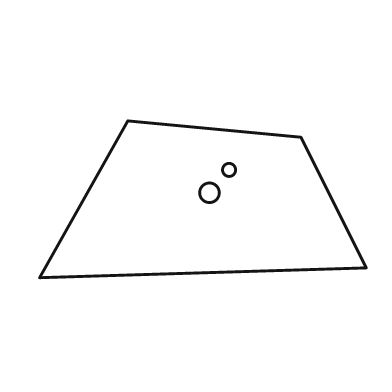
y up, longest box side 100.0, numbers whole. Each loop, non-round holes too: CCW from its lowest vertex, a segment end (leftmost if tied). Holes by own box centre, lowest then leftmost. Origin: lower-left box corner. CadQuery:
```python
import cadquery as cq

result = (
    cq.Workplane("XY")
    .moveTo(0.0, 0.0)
    .lineTo(100.0, 3.0)
    .lineTo(80.0, 43.0)
    .lineTo(27.0, 48.0)
    .close()
    .moveTo(52.0, 26.0)
    .circle(3.0)
    .moveTo(58.0, 33.0)
    .circle(2.0)
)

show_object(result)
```